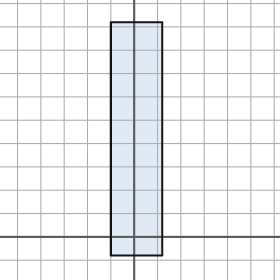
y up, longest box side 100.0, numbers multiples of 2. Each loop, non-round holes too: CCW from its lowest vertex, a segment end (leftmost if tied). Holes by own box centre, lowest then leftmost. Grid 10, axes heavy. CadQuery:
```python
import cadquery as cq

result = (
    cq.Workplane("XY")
    .moveTo(-10.0, -8.0)
    .lineTo(12.0, -8.0)
    .lineTo(12.0, 92.0)
    .lineTo(-10.0, 92.0)
    .close()
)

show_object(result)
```